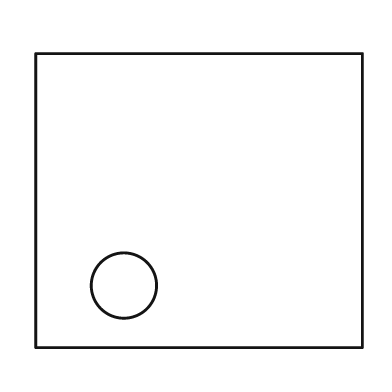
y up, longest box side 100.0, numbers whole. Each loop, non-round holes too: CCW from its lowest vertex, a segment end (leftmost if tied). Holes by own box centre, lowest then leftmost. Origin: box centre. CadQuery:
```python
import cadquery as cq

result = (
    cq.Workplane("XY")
    .moveTo(-50.0, -45.0)
    .lineTo(50.0, -45.0)
    .lineTo(50.0, 45.0)
    .lineTo(-50.0, 45.0)
    .close()
    .moveTo(-23.0, -26.0)
    .circle(10.0)
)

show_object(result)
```